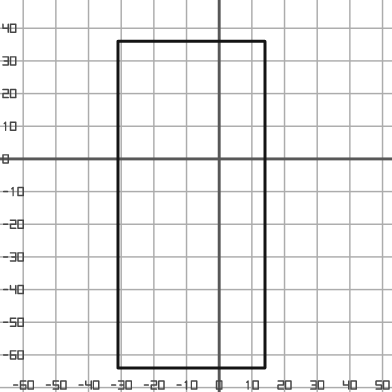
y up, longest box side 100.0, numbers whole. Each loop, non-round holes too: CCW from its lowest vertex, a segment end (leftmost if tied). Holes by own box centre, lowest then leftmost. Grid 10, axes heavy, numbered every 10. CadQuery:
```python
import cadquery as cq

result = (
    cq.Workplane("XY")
    .moveTo(-31.0, -64.0)
    .lineTo(14.0, -64.0)
    .lineTo(14.0, 36.0)
    .lineTo(-31.0, 36.0)
    .close()
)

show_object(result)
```